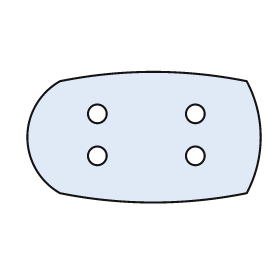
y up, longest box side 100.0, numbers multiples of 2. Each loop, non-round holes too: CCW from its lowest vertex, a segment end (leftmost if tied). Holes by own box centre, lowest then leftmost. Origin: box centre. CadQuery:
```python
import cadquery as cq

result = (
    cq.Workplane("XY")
    .moveTo(-36.0, -24.0)
    .threePointArc((4.0, -28.0), (44.0, -24.0))
    .threePointArc((50.0, 0.0), (44.0, 24.0))
    .threePointArc((4.0, 28.0), (-36.0, 24.0))
    .threePointArc((-50.0, 0.0), (-36.0, -24.0))
    .close()
    .moveTo(-20.0, -8.0)
    .circle(4.0)
    .moveTo(22.0, -8.0)
    .circle(4.0)
    .moveTo(-20.0, 10.0)
    .circle(4.0)
    .moveTo(22.0, 10.0)
    .circle(4.0)
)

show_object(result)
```